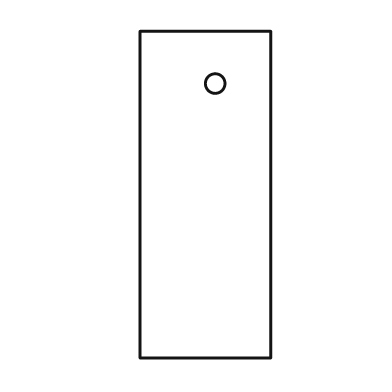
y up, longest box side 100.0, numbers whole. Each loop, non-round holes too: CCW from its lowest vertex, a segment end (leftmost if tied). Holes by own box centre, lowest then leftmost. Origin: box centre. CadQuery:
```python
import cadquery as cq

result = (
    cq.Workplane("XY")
    .moveTo(-20.0, -50.0)
    .lineTo(20.0, -50.0)
    .lineTo(20.0, 50.0)
    .lineTo(-20.0, 50.0)
    .close()
    .moveTo(3.0, 34.0)
    .circle(3.0)
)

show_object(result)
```